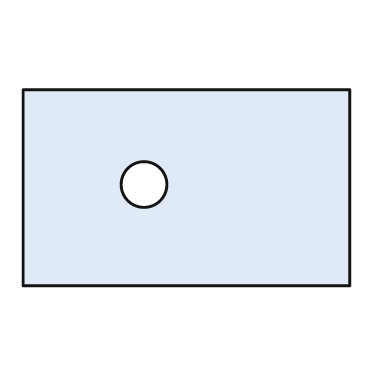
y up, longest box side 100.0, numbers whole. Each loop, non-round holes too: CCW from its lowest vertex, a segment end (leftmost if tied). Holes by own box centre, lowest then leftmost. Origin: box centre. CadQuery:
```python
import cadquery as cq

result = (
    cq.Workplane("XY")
    .moveTo(-50.0, -30.0)
    .lineTo(50.0, -30.0)
    .lineTo(50.0, 30.0)
    .lineTo(-50.0, 30.0)
    .close()
    .moveTo(-13.0, 1.0)
    .circle(7.0)
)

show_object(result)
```